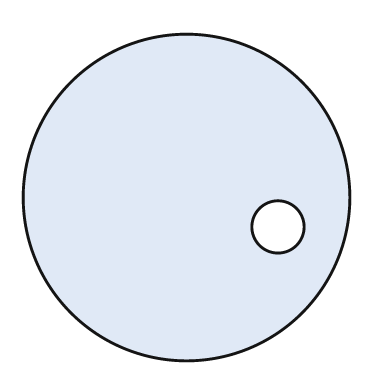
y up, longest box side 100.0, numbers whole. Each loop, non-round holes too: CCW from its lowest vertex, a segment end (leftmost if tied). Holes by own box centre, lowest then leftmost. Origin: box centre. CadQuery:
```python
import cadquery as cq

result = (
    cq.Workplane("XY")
    .moveTo(0.0, 0.0)
    .circle(50.0)
    .moveTo(28.0, -9.0)
    .circle(8.0)
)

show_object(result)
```